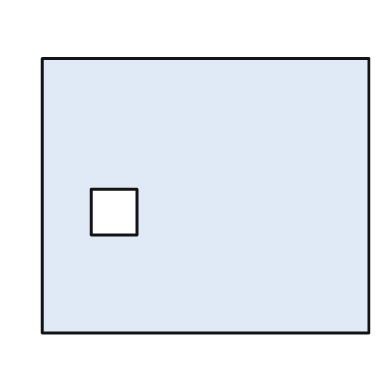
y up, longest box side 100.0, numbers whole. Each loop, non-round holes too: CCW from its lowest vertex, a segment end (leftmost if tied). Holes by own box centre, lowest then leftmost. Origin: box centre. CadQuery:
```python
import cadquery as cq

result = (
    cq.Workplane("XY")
    .moveTo(-50.0, -42.0)
    .lineTo(50.0, -42.0)
    .lineTo(50.0, 42.0)
    .lineTo(-50.0, 42.0)
    .close()
    .moveTo(-35.0, -12.0)
    .lineTo(-21.0, -12.0)
    .lineTo(-21.0, 2.0)
    .lineTo(-35.0, 2.0)
    .close()
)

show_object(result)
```